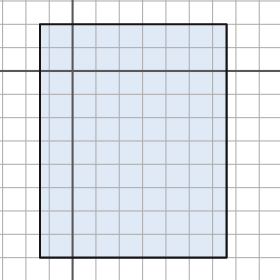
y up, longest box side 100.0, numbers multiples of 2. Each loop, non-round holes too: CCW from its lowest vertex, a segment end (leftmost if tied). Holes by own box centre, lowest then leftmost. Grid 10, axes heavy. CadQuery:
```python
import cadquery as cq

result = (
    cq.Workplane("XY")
    .moveTo(-14.0, -80.0)
    .lineTo(66.0, -80.0)
    .lineTo(66.0, 20.0)
    .lineTo(-14.0, 20.0)
    .close()
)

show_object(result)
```